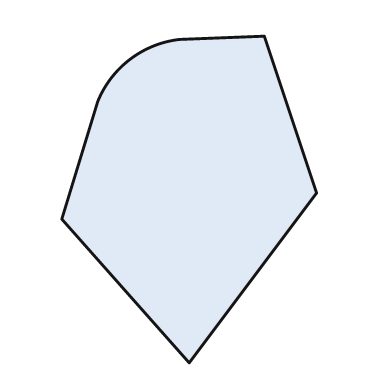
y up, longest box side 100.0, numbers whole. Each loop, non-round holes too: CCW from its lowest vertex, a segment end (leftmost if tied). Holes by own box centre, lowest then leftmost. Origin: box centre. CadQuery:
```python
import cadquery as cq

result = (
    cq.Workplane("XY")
    .moveTo(0.0, -50.0)
    .lineTo(39.0, 2.0)
    .lineTo(23.0, 50.0)
    .lineTo(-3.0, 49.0)
    .threePointArc((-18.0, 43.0), (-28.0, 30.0))
    .lineTo(-39.0, -6.0)
    .close()
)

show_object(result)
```